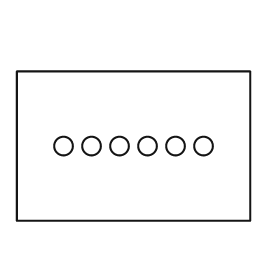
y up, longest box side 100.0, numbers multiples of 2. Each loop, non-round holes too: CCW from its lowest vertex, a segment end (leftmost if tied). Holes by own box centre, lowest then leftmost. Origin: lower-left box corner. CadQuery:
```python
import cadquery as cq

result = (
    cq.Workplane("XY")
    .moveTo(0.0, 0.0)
    .lineTo(100.0, 0.0)
    .lineTo(100.0, 64.0)
    .lineTo(0.0, 64.0)
    .close()
    .moveTo(20.0, 32.0)
    .circle(4.0)
    .moveTo(32.0, 32.0)
    .circle(4.0)
    .moveTo(44.0, 32.0)
    .circle(4.0)
    .moveTo(56.0, 32.0)
    .circle(4.0)
    .moveTo(68.0, 32.0)
    .circle(4.0)
    .moveTo(80.0, 32.0)
    .circle(4.0)
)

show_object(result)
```